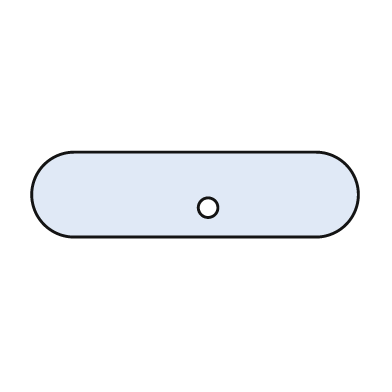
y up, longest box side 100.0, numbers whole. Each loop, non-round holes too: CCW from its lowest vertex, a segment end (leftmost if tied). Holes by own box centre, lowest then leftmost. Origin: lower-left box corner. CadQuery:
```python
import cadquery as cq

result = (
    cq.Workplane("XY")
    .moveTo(13.0, 0.0)
    .lineTo(87.0, 0.0)
    .threePointArc((100.0, 13.0), (87.0, 26.0))
    .lineTo(13.0, 26.0)
    .threePointArc((0.0, 13.0), (13.0, 0.0))
    .close()
    .moveTo(54.0, 9.0)
    .circle(3.0)
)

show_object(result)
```